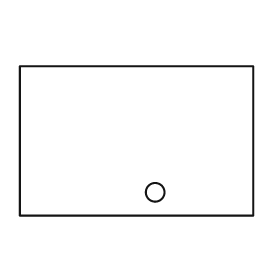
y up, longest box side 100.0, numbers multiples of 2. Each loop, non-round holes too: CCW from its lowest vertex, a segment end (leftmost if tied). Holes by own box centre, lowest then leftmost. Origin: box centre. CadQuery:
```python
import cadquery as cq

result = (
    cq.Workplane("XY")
    .moveTo(-50.0, -32.0)
    .lineTo(50.0, -32.0)
    .lineTo(50.0, 32.0)
    .lineTo(-50.0, 32.0)
    .close()
    .moveTo(8.0, -22.0)
    .circle(4.0)
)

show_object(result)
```